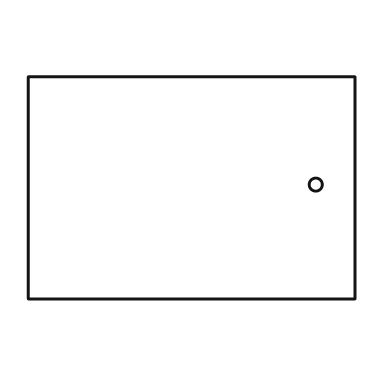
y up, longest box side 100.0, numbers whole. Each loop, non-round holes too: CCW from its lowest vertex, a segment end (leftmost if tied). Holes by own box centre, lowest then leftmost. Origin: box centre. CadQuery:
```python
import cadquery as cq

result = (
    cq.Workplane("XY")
    .moveTo(-50.0, -34.0)
    .lineTo(50.0, -34.0)
    .lineTo(50.0, 34.0)
    .lineTo(-50.0, 34.0)
    .close()
    .moveTo(38.0, 1.0)
    .circle(2.0)
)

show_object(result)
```